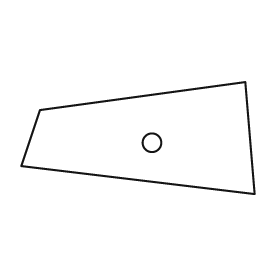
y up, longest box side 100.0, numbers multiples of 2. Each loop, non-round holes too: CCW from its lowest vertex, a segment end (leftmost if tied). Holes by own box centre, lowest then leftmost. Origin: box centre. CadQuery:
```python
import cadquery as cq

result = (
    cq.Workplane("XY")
    .moveTo(50.0, -24.0)
    .lineTo(46.0, 24.0)
    .lineTo(-42.0, 12.0)
    .lineTo(-50.0, -12.0)
    .close()
    .moveTo(6.0, -2.0)
    .circle(4.0)
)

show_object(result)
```